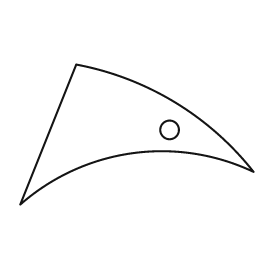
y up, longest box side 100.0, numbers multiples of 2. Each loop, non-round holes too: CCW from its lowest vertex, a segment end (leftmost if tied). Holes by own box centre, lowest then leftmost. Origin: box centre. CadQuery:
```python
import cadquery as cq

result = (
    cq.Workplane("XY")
    .moveTo(-50.0, -30.0)
    .threePointArc((-2.0, -8.0), (50.0, -16.0))
    .threePointArc((16.0, 14.0), (-26.0, 30.0))
    .close()
    .moveTo(14.0, 2.0)
    .circle(4.0)
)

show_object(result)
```